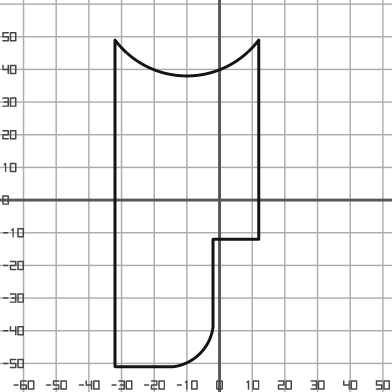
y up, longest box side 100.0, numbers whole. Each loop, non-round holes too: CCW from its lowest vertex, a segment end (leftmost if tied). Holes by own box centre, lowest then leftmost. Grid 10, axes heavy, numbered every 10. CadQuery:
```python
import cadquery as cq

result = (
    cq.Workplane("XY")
    .moveTo(-32.0, -51.0)
    .lineTo(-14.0, -51.0)
    .threePointArc((-6.0, -47.0), (-2.0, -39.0))
    .lineTo(-2.0, -12.0)
    .lineTo(12.0, -12.0)
    .lineTo(12.0, 49.0)
    .threePointArc((-10.0, 38.0), (-32.0, 49.0))
    .close()
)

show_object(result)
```